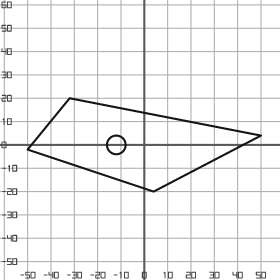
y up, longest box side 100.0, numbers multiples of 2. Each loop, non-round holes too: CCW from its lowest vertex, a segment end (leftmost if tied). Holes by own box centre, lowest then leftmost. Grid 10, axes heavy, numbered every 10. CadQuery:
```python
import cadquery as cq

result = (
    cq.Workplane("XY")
    .moveTo(4.0, -20.0)
    .lineTo(50.0, 4.0)
    .lineTo(-32.0, 20.0)
    .lineTo(-50.0, -2.0)
    .close()
    .moveTo(-12.0, 0.0)
    .circle(4.0)
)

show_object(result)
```